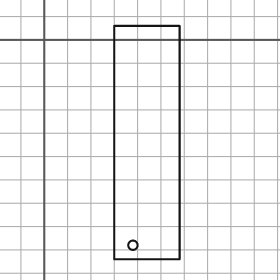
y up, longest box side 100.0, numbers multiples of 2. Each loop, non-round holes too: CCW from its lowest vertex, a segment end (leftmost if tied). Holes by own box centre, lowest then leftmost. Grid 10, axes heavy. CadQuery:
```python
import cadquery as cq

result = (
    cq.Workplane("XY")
    .moveTo(30.0, -94.0)
    .lineTo(58.0, -94.0)
    .lineTo(58.0, 6.0)
    .lineTo(30.0, 6.0)
    .close()
    .moveTo(38.0, -88.0)
    .circle(2.0)
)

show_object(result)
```